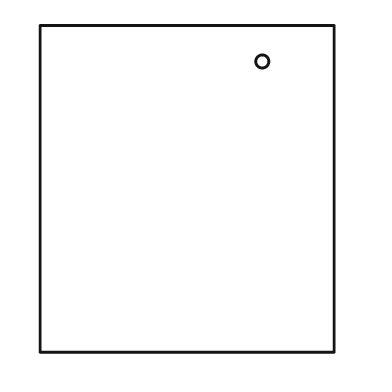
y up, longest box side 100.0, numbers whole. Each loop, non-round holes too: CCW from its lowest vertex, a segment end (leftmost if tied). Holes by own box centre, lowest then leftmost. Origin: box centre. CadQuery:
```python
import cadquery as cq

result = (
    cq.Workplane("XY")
    .moveTo(-45.0, -50.0)
    .lineTo(45.0, -50.0)
    .lineTo(45.0, 50.0)
    .lineTo(-45.0, 50.0)
    .close()
    .moveTo(23.0, 39.0)
    .circle(2.0)
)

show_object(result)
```